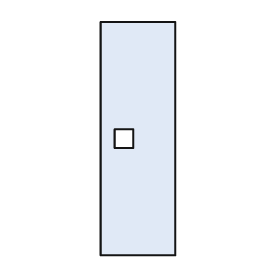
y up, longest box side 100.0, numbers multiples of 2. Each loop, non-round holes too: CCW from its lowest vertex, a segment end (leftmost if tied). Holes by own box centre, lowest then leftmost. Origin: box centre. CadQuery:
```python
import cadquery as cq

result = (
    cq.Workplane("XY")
    .moveTo(-16.0, -50.0)
    .lineTo(16.0, -50.0)
    .lineTo(16.0, 50.0)
    .lineTo(-16.0, 50.0)
    .close()
    .moveTo(-10.0, -4.0)
    .lineTo(-2.0, -4.0)
    .lineTo(-2.0, 4.0)
    .lineTo(-10.0, 4.0)
    .close()
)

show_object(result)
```